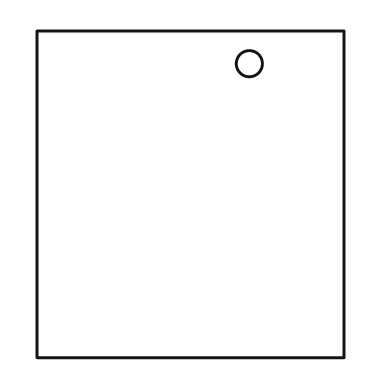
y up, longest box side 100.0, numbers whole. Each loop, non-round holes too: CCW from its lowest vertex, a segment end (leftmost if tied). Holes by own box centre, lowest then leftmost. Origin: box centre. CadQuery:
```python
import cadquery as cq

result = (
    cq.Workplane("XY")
    .moveTo(-47.0, -50.0)
    .lineTo(47.0, -50.0)
    .lineTo(47.0, 50.0)
    .lineTo(-47.0, 50.0)
    .close()
    .moveTo(18.0, 40.0)
    .circle(4.0)
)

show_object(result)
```